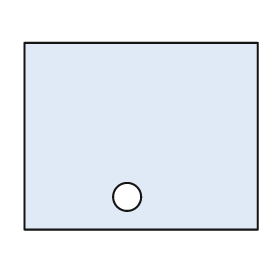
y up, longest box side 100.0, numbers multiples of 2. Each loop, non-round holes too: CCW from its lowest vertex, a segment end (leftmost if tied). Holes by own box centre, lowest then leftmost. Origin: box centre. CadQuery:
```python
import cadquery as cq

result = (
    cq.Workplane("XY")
    .moveTo(-50.0, -40.0)
    .lineTo(50.0, -40.0)
    .lineTo(50.0, 40.0)
    .lineTo(-50.0, 40.0)
    .close()
    .moveTo(-6.0, -26.0)
    .circle(6.0)
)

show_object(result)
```